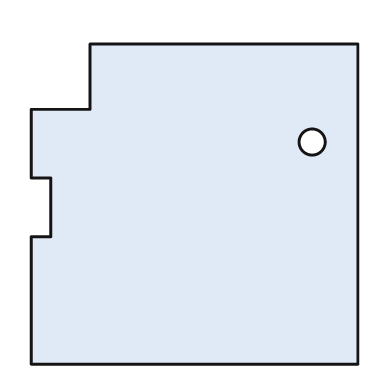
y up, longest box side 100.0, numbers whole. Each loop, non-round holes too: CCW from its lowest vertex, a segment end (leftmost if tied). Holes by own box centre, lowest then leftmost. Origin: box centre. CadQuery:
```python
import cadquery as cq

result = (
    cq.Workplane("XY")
    .moveTo(-50.0, -49.0)
    .lineTo(50.0, -49.0)
    .lineTo(50.0, 49.0)
    .lineTo(-32.0, 49.0)
    .lineTo(-32.0, 29.0)
    .lineTo(-50.0, 29.0)
    .lineTo(-50.0, 8.0)
    .lineTo(-44.0, 8.0)
    .lineTo(-44.0, -10.0)
    .lineTo(-50.0, -10.0)
    .close()
    .moveTo(36.0, 19.0)
    .circle(4.0)
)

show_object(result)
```